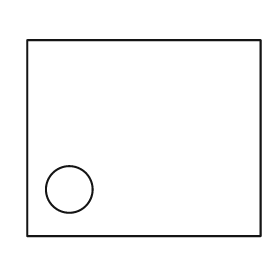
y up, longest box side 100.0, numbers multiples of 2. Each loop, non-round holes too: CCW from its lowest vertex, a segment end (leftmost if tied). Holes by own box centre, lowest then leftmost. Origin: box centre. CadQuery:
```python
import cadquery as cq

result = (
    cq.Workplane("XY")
    .moveTo(-50.0, -42.0)
    .lineTo(50.0, -42.0)
    .lineTo(50.0, 42.0)
    .lineTo(-50.0, 42.0)
    .close()
    .moveTo(-32.0, -22.0)
    .circle(10.0)
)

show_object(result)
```